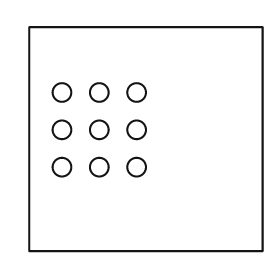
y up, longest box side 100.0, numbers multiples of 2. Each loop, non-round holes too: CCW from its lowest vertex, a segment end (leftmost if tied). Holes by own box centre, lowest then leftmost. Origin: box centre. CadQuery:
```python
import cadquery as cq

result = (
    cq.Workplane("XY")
    .moveTo(-50.0, -48.0)
    .lineTo(50.0, -48.0)
    .lineTo(50.0, 48.0)
    .lineTo(-50.0, 48.0)
    .close()
    .moveTo(-36.0, -12.0)
    .circle(4.0)
    .moveTo(-20.0, -12.0)
    .circle(4.0)
    .moveTo(-4.0, -12.0)
    .circle(4.0)
    .moveTo(-36.0, 4.0)
    .circle(4.0)
    .moveTo(-20.0, 4.0)
    .circle(4.0)
    .moveTo(-4.0, 4.0)
    .circle(4.0)
    .moveTo(-36.0, 20.0)
    .circle(4.0)
    .moveTo(-20.0, 20.0)
    .circle(4.0)
    .moveTo(-4.0, 20.0)
    .circle(4.0)
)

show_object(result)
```